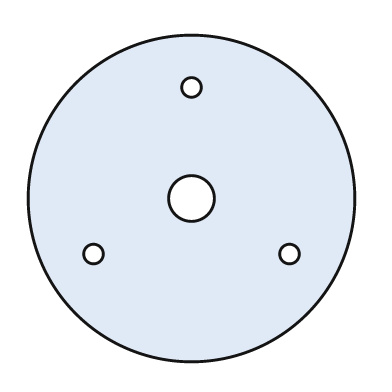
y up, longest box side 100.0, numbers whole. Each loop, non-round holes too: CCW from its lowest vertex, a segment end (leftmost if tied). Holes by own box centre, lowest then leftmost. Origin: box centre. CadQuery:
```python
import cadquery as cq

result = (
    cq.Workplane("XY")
    .moveTo(0.0, 0.0)
    .circle(50.0)
    .moveTo(-30.0, -17.0)
    .circle(3.0)
    .moveTo(30.0, -17.0)
    .circle(3.0)
    .moveTo(0.0, 0.0)
    .circle(7.0)
    .moveTo(0.0, 34.0)
    .circle(3.0)
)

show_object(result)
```